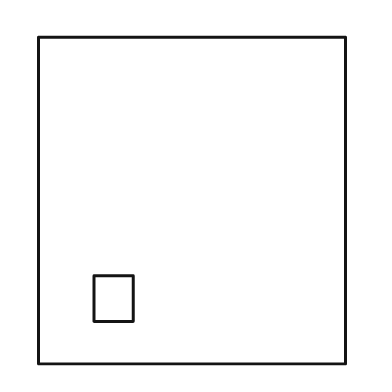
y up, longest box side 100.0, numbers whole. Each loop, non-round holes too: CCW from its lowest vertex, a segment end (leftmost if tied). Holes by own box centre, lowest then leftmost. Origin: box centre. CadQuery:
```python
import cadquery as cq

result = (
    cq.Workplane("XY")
    .moveTo(-47.0, -50.0)
    .lineTo(47.0, -50.0)
    .lineTo(47.0, 50.0)
    .lineTo(-47.0, 50.0)
    .close()
    .moveTo(-30.0, -37.0)
    .lineTo(-18.0, -37.0)
    .lineTo(-18.0, -23.0)
    .lineTo(-30.0, -23.0)
    .close()
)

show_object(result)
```